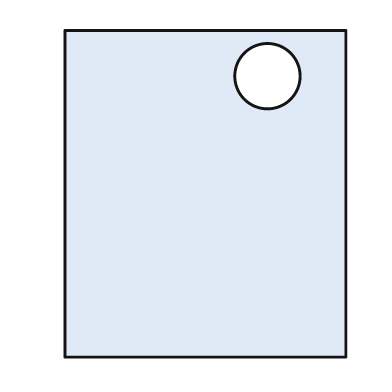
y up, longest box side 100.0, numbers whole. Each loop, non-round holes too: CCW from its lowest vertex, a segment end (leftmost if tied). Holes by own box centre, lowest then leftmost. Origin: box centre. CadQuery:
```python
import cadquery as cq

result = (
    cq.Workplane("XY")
    .moveTo(-43.0, -50.0)
    .lineTo(43.0, -50.0)
    .lineTo(43.0, 50.0)
    .lineTo(-43.0, 50.0)
    .close()
    .moveTo(19.0, 36.0)
    .circle(10.0)
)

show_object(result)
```